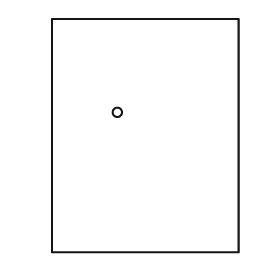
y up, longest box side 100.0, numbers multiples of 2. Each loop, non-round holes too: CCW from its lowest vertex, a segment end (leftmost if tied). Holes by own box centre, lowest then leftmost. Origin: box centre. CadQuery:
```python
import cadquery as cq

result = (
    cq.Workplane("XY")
    .moveTo(-40.0, -50.0)
    .lineTo(40.0, -50.0)
    .lineTo(40.0, 50.0)
    .lineTo(-40.0, 50.0)
    .close()
    .moveTo(-12.0, 10.0)
    .circle(2.0)
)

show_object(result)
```